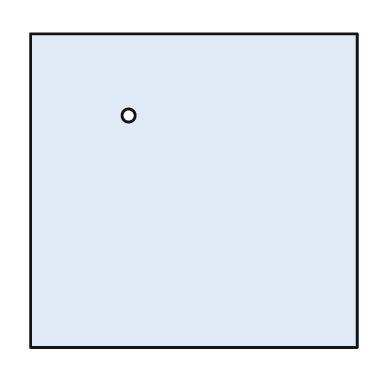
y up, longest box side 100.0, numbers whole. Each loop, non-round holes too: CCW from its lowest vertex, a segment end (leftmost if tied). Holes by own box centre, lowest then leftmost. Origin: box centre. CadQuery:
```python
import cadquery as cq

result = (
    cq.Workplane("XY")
    .moveTo(-50.0, -48.0)
    .lineTo(50.0, -48.0)
    .lineTo(50.0, 48.0)
    .lineTo(-50.0, 48.0)
    .close()
    .moveTo(-20.0, 23.0)
    .circle(2.0)
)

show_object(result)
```